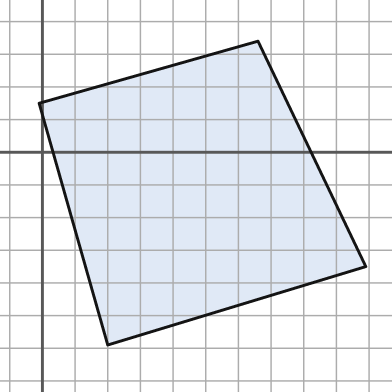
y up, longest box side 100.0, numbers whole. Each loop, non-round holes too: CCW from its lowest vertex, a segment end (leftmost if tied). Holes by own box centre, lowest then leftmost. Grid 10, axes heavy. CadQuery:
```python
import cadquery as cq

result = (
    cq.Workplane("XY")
    .moveTo(20.0, -59.0)
    .lineTo(99.0, -35.0)
    .lineTo(66.0, 34.0)
    .lineTo(-1.0, 15.0)
    .close()
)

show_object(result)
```